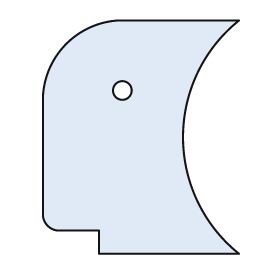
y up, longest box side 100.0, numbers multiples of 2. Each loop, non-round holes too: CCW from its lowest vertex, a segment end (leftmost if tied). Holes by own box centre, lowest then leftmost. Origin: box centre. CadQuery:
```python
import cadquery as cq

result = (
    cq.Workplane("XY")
    .moveTo(-18.0, -50.0)
    .lineTo(42.0, -50.0)
    .threePointArc((18.0, 0.0), (42.0, 50.0))
    .lineTo(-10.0, 50.0)
    .threePointArc((-32.0, 40.0), (-42.0, 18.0))
    .lineTo(-42.0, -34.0)
    .threePointArc((-40.0, -38.0), (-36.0, -40.0))
    .lineTo(-18.0, -40.0)
    .close()
    .moveTo(-8.0, 20.0)
    .circle(4.0)
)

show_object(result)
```